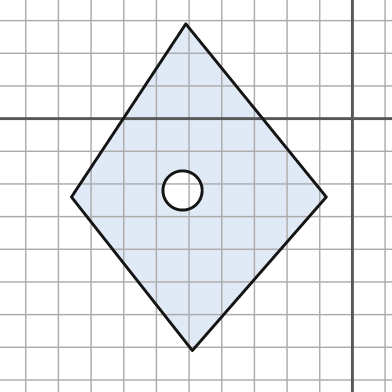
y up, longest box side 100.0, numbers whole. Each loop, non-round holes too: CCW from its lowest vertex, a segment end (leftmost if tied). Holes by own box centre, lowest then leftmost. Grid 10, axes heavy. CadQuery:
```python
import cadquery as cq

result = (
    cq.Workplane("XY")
    .moveTo(-49.0, -71.0)
    .lineTo(-8.0, -24.0)
    .lineTo(-51.0, 29.0)
    .lineTo(-86.0, -24.0)
    .close()
    .moveTo(-52.0, -22.0)
    .circle(6.0)
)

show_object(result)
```